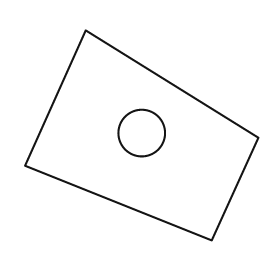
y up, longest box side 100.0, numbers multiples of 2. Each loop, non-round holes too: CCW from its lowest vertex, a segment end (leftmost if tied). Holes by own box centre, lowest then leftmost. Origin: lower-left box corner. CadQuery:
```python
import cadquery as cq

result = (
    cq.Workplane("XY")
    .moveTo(80.0, 0.0)
    .lineTo(100.0, 44.0)
    .lineTo(26.0, 90.0)
    .lineTo(0.0, 32.0)
    .close()
    .moveTo(50.0, 46.0)
    .circle(10.0)
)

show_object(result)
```